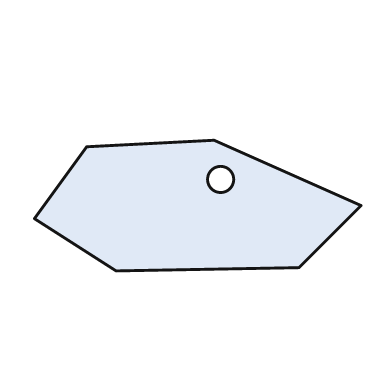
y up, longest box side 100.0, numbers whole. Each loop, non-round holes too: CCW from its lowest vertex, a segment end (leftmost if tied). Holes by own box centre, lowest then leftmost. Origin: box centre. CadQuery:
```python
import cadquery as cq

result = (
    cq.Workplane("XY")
    .moveTo(-25.0, -20.0)
    .lineTo(31.0, -19.0)
    .lineTo(50.0, 0.0)
    .lineTo(5.0, 20.0)
    .lineTo(-34.0, 18.0)
    .lineTo(-50.0, -4.0)
    .close()
    .moveTo(7.0, 8.0)
    .circle(4.0)
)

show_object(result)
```